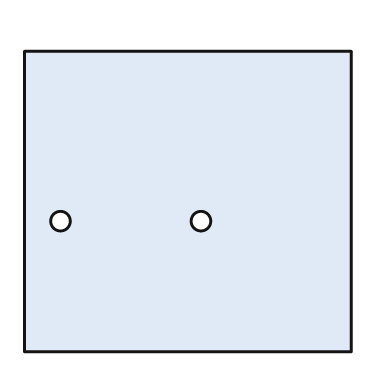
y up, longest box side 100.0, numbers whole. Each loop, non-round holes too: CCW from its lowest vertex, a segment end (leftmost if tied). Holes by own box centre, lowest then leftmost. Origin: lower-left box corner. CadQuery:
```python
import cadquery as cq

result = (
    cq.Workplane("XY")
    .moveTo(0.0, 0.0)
    .lineTo(100.0, 0.0)
    .lineTo(100.0, 92.0)
    .lineTo(0.0, 92.0)
    .close()
    .moveTo(11.0, 40.0)
    .circle(3.0)
    .moveTo(54.0, 40.0)
    .circle(3.0)
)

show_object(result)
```